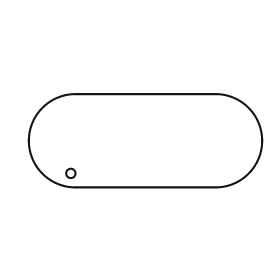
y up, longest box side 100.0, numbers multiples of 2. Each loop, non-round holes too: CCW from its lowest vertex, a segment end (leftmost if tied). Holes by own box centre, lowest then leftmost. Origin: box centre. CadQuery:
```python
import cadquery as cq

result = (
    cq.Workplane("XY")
    .moveTo(-30.0, -20.0)
    .lineTo(30.0, -20.0)
    .threePointArc((50.0, 0.0), (30.0, 20.0))
    .lineTo(-30.0, 20.0)
    .threePointArc((-50.0, 0.0), (-30.0, -20.0))
    .close()
    .moveTo(-32.0, -14.0)
    .circle(2.0)
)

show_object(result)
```